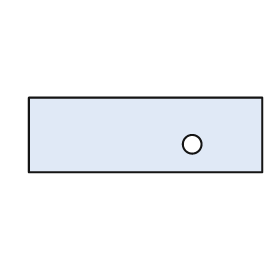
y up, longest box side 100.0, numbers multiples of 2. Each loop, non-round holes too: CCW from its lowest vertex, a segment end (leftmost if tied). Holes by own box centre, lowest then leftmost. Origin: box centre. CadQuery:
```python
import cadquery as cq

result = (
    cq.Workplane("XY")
    .moveTo(-50.0, -16.0)
    .lineTo(50.0, -16.0)
    .lineTo(50.0, 16.0)
    .lineTo(-50.0, 16.0)
    .close()
    .moveTo(20.0, -4.0)
    .circle(4.0)
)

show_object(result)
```